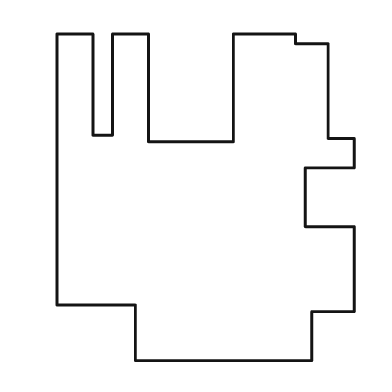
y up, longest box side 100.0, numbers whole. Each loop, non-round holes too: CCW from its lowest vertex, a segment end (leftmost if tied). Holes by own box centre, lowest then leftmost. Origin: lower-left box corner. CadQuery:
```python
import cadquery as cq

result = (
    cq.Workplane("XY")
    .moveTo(24.0, 0.0)
    .lineTo(78.0, 0.0)
    .lineTo(78.0, 15.0)
    .lineTo(91.0, 15.0)
    .lineTo(91.0, 41.0)
    .lineTo(76.0, 41.0)
    .lineTo(76.0, 59.0)
    .lineTo(91.0, 59.0)
    .lineTo(91.0, 68.0)
    .lineTo(83.0, 68.0)
    .lineTo(83.0, 97.0)
    .lineTo(73.0, 97.0)
    .lineTo(73.0, 100.0)
    .lineTo(54.0, 100.0)
    .lineTo(54.0, 67.0)
    .lineTo(28.0, 67.0)
    .lineTo(28.0, 100.0)
    .lineTo(17.0, 100.0)
    .lineTo(17.0, 69.0)
    .lineTo(11.0, 69.0)
    .lineTo(11.0, 100.0)
    .lineTo(0.0, 100.0)
    .lineTo(0.0, 17.0)
    .lineTo(24.0, 17.0)
    .close()
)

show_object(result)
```